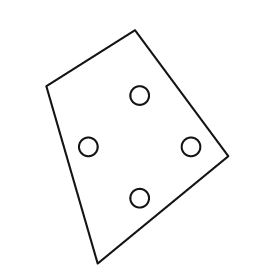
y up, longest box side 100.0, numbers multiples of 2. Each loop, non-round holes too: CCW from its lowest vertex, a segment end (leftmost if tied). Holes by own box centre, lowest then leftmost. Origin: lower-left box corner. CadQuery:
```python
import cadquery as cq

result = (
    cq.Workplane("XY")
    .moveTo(22.0, 0.0)
    .lineTo(78.0, 46.0)
    .lineTo(38.0, 100.0)
    .lineTo(0.0, 76.0)
    .close()
    .moveTo(40.0, 28.0)
    .circle(4.0)
    .moveTo(18.0, 50.0)
    .circle(4.0)
    .moveTo(62.0, 50.0)
    .circle(4.0)
    .moveTo(40.0, 72.0)
    .circle(4.0)
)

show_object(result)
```